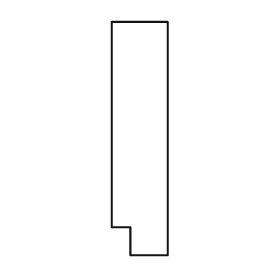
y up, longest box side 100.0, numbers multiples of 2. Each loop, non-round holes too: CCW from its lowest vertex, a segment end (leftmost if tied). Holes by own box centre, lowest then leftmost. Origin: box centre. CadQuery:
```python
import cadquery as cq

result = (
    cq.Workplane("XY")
    .moveTo(-4.0, -50.0)
    .lineTo(12.0, -50.0)
    .lineTo(12.0, 50.0)
    .lineTo(-12.0, 50.0)
    .lineTo(-12.0, -38.0)
    .lineTo(-4.0, -38.0)
    .close()
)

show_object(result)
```